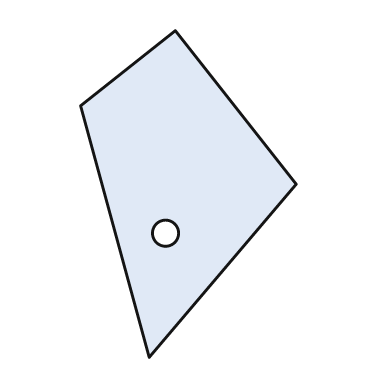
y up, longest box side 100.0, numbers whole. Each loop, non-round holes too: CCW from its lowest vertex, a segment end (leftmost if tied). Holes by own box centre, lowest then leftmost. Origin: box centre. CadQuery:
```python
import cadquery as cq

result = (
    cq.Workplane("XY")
    .moveTo(-12.0, -50.0)
    .lineTo(33.0, 3.0)
    .lineTo(-4.0, 50.0)
    .lineTo(-33.0, 27.0)
    .close()
    .moveTo(-7.0, -12.0)
    .circle(4.0)
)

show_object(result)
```